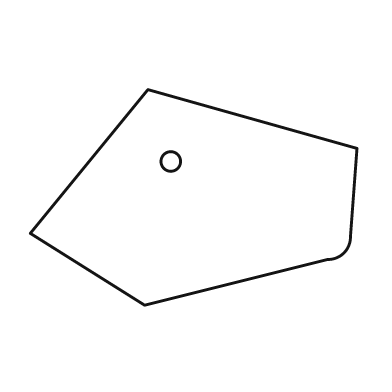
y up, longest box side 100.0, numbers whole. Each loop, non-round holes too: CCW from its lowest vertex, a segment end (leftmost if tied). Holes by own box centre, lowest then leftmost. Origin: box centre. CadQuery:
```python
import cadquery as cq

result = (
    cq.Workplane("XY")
    .moveTo(-15.0, -33.0)
    .lineTo(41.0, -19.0)
    .threePointArc((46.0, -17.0), (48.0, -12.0))
    .lineTo(50.0, 15.0)
    .lineTo(-14.0, 33.0)
    .lineTo(-50.0, -11.0)
    .close()
    .moveTo(-7.0, 11.0)
    .circle(3.0)
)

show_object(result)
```